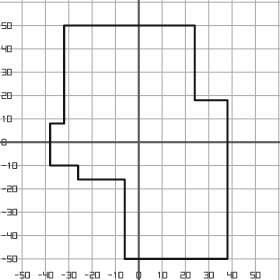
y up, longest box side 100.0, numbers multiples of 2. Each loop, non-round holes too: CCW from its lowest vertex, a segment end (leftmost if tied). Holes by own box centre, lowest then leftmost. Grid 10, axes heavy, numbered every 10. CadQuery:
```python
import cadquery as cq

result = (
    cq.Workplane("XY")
    .moveTo(-6.0, -50.0)
    .lineTo(38.0, -50.0)
    .lineTo(38.0, 18.0)
    .lineTo(24.0, 18.0)
    .lineTo(24.0, 50.0)
    .lineTo(-32.0, 50.0)
    .lineTo(-32.0, 8.0)
    .lineTo(-38.0, 8.0)
    .lineTo(-38.0, -10.0)
    .lineTo(-26.0, -10.0)
    .lineTo(-26.0, -16.0)
    .lineTo(-6.0, -16.0)
    .close()
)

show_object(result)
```